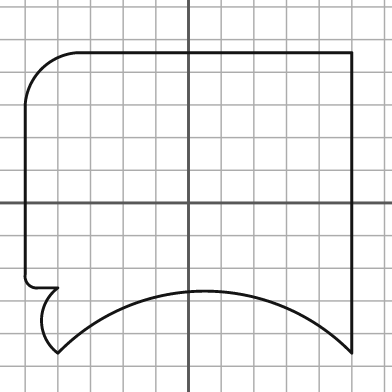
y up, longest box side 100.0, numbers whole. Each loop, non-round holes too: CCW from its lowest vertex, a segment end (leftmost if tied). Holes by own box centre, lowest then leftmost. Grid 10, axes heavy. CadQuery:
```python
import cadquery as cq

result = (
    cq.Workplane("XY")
    .moveTo(-40.0, -46.0)
    .threePointArc((5.0, -27.0), (50.0, -46.0))
    .lineTo(50.0, 46.0)
    .lineTo(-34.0, 46.0)
    .threePointArc((-45.0, 41.0), (-50.0, 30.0))
    .lineTo(-50.0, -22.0)
    .threePointArc((-49.0, -25.0), (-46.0, -26.0))
    .lineTo(-40.0, -26.0)
    .threePointArc((-45.0, -36.0), (-40.0, -46.0))
    .close()
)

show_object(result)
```